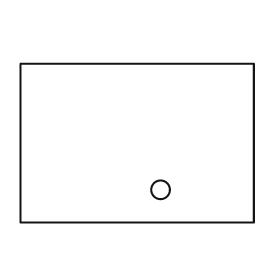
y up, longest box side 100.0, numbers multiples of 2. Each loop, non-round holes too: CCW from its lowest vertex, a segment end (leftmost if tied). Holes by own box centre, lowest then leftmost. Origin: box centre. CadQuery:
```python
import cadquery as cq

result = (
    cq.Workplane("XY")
    .moveTo(-50.0, -34.0)
    .lineTo(50.0, -34.0)
    .lineTo(50.0, 34.0)
    .lineTo(-50.0, 34.0)
    .close()
    .moveTo(10.0, -20.0)
    .circle(4.0)
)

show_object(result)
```